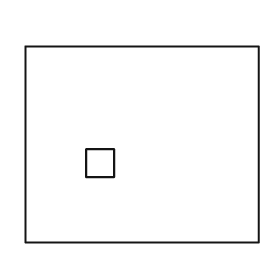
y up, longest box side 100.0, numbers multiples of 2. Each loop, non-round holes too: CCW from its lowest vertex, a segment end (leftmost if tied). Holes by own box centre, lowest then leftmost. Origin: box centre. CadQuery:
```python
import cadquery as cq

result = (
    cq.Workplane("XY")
    .moveTo(-50.0, -42.0)
    .lineTo(50.0, -42.0)
    .lineTo(50.0, 42.0)
    .lineTo(-50.0, 42.0)
    .close()
    .moveTo(-24.0, -14.0)
    .lineTo(-12.0, -14.0)
    .lineTo(-12.0, -2.0)
    .lineTo(-24.0, -2.0)
    .close()
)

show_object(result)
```